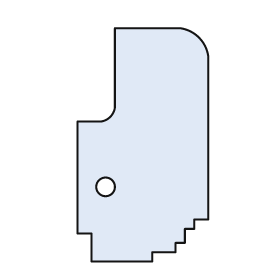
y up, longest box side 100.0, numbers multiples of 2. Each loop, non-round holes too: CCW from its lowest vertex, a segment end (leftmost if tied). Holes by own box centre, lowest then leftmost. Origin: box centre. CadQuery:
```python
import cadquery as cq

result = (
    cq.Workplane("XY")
    .moveTo(-22.0, -50.0)
    .lineTo(4.0, -50.0)
    .lineTo(4.0, -46.0)
    .lineTo(14.0, -46.0)
    .lineTo(14.0, -42.0)
    .lineTo(18.0, -42.0)
    .lineTo(18.0, -36.0)
    .lineTo(22.0, -36.0)
    .lineTo(22.0, -32.0)
    .lineTo(28.0, -32.0)
    .lineTo(28.0, 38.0)
    .threePointArc((24.0, 46.0), (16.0, 50.0))
    .lineTo(-12.0, 50.0)
    .lineTo(-12.0, 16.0)
    .threePointArc((-14.0, 12.0), (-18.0, 10.0))
    .lineTo(-28.0, 10.0)
    .lineTo(-28.0, -38.0)
    .lineTo(-22.0, -38.0)
    .close()
    .moveTo(-16.0, -18.0)
    .circle(4.0)
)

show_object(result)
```